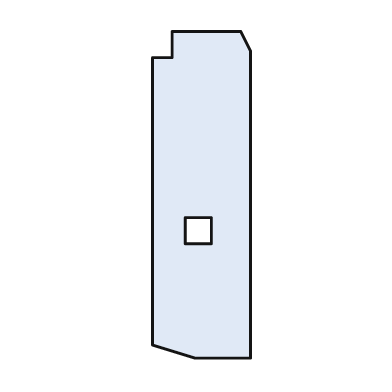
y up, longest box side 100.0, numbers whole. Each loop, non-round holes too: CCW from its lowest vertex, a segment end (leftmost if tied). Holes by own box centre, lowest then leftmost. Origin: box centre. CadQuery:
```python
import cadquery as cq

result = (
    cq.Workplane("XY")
    .moveTo(-2.0, -50.0)
    .lineTo(15.0, -50.0)
    .lineTo(15.0, 44.0)
    .lineTo(12.0, 50.0)
    .lineTo(-9.0, 50.0)
    .lineTo(-9.0, 42.0)
    .lineTo(-15.0, 42.0)
    .lineTo(-15.0, -46.0)
    .close()
    .moveTo(-5.0, -15.0)
    .lineTo(3.0, -15.0)
    .lineTo(3.0, -7.0)
    .lineTo(-5.0, -7.0)
    .close()
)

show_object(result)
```